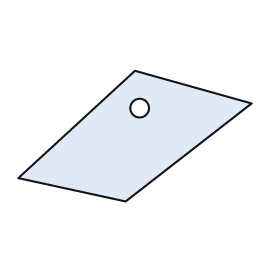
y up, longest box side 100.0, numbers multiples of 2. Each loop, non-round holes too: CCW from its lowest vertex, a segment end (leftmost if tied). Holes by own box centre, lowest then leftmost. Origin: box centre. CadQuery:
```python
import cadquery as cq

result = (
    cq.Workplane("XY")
    .moveTo(-4.0, -28.0)
    .lineTo(50.0, 14.0)
    .lineTo(0.0, 28.0)
    .lineTo(-50.0, -18.0)
    .close()
    .moveTo(2.0, 12.0)
    .circle(4.0)
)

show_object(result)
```